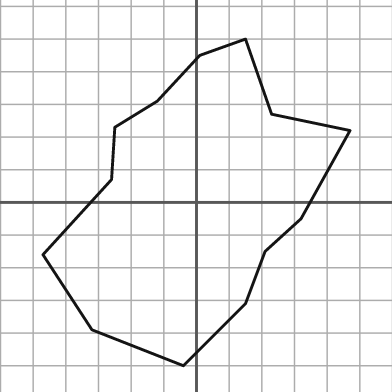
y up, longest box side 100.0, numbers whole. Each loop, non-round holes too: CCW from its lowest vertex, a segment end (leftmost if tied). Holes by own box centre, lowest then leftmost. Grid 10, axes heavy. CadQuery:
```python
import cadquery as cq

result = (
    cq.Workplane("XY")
    .moveTo(-4.0, -50.0)
    .lineTo(15.0, -31.0)
    .lineTo(21.0, -15.0)
    .lineTo(32.0, -5.0)
    .lineTo(47.0, 22.0)
    .lineTo(23.0, 27.0)
    .lineTo(15.0, 50.0)
    .lineTo(1.0, 45.0)
    .lineTo(-12.0, 31.0)
    .lineTo(-25.0, 23.0)
    .lineTo(-26.0, 7.0)
    .lineTo(-47.0, -16.0)
    .lineTo(-32.0, -39.0)
    .close()
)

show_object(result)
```